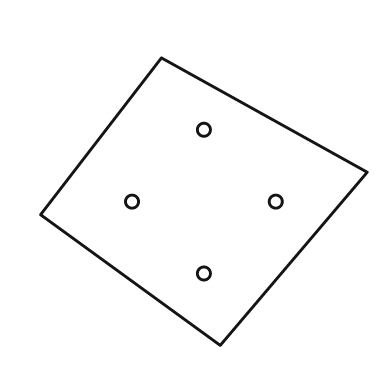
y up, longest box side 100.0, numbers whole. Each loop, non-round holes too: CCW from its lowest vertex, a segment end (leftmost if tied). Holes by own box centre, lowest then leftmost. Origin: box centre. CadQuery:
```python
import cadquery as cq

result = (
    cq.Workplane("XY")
    .moveTo(5.0, -44.0)
    .lineTo(50.0, 9.0)
    .lineTo(-13.0, 44.0)
    .lineTo(-50.0, -4.0)
    .close()
    .moveTo(0.0, -22.0)
    .circle(2.0)
    .moveTo(-22.0, 0.0)
    .circle(2.0)
    .moveTo(22.0, 0.0)
    .circle(2.0)
    .moveTo(0.0, 22.0)
    .circle(2.0)
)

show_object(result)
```